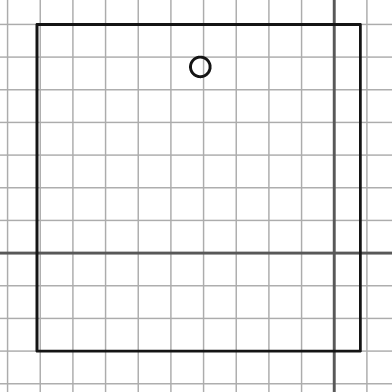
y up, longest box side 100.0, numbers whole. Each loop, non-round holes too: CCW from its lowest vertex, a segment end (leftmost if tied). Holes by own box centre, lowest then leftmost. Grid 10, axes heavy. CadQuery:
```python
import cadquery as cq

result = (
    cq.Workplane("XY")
    .moveTo(-91.0, -30.0)
    .lineTo(8.0, -30.0)
    .lineTo(8.0, 70.0)
    .lineTo(-91.0, 70.0)
    .close()
    .moveTo(-41.0, 57.0)
    .circle(3.0)
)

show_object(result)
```